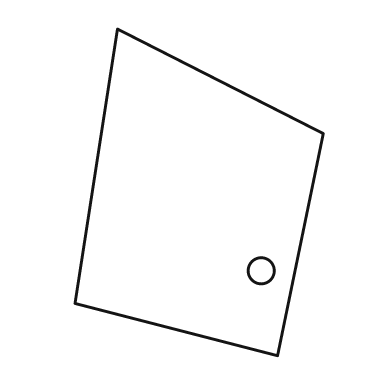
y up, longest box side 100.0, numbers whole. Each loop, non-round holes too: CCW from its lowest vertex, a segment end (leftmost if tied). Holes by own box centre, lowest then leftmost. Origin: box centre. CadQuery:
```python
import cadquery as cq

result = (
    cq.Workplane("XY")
    .moveTo(24.0, -50.0)
    .lineTo(38.0, 18.0)
    .lineTo(-25.0, 50.0)
    .lineTo(-38.0, -34.0)
    .close()
    .moveTo(19.0, -24.0)
    .circle(4.0)
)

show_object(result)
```